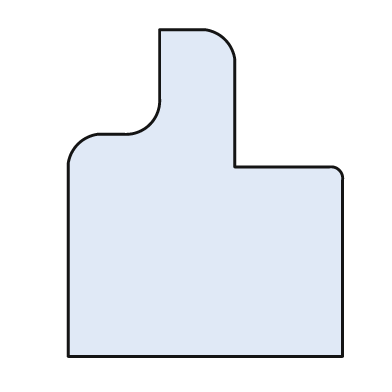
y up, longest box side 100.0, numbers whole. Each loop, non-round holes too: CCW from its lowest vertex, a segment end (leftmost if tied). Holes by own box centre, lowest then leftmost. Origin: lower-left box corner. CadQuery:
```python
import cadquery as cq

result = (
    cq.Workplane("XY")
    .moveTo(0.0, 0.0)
    .lineTo(84.0, 0.0)
    .lineTo(84.0, 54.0)
    .threePointArc((83.0, 57.0), (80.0, 58.0))
    .lineTo(51.0, 58.0)
    .lineTo(51.0, 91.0)
    .threePointArc((48.0, 97.0), (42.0, 100.0))
    .lineTo(28.0, 100.0)
    .lineTo(28.0, 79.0)
    .threePointArc((25.0, 71.0), (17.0, 68.0))
    .lineTo(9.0, 68.0)
    .threePointArc((3.0, 65.0), (0.0, 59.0))
    .close()
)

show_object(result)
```